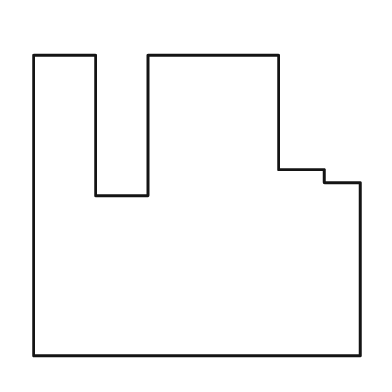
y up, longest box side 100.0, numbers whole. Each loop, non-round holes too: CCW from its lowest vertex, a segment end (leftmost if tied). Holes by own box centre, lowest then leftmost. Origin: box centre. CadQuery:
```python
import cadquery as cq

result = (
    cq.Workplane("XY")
    .moveTo(-50.0, -46.0)
    .lineTo(50.0, -46.0)
    .lineTo(50.0, 7.0)
    .lineTo(39.0, 7.0)
    .lineTo(39.0, 11.0)
    .lineTo(25.0, 11.0)
    .lineTo(25.0, 46.0)
    .lineTo(-15.0, 46.0)
    .lineTo(-15.0, 3.0)
    .lineTo(-31.0, 3.0)
    .lineTo(-31.0, 46.0)
    .lineTo(-50.0, 46.0)
    .close()
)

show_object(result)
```